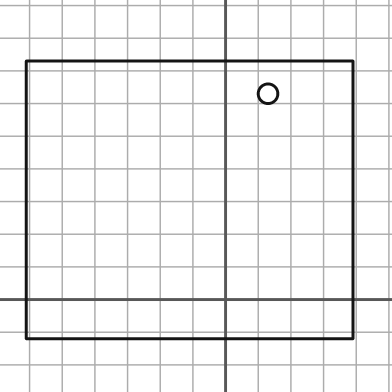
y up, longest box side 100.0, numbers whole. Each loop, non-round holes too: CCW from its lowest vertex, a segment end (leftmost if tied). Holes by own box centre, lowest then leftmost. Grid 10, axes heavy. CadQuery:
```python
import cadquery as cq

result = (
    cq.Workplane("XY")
    .moveTo(-61.0, -12.0)
    .lineTo(39.0, -12.0)
    .lineTo(39.0, 73.0)
    .lineTo(-61.0, 73.0)
    .close()
    .moveTo(13.0, 63.0)
    .circle(3.0)
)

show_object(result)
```